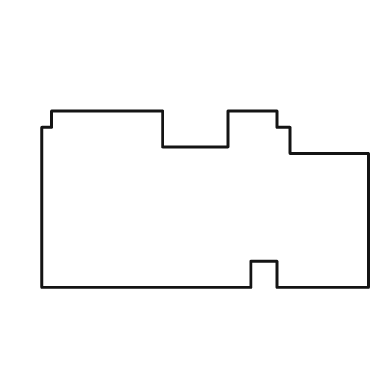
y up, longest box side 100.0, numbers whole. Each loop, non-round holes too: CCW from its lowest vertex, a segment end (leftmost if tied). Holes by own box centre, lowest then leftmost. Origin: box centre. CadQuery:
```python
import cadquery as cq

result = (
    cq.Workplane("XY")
    .moveTo(-50.0, -27.0)
    .lineTo(14.0, -27.0)
    .lineTo(14.0, -19.0)
    .lineTo(22.0, -19.0)
    .lineTo(22.0, -27.0)
    .lineTo(50.0, -27.0)
    .lineTo(50.0, 14.0)
    .lineTo(26.0, 14.0)
    .lineTo(26.0, 22.0)
    .lineTo(22.0, 22.0)
    .lineTo(22.0, 27.0)
    .lineTo(7.0, 27.0)
    .lineTo(7.0, 16.0)
    .lineTo(-13.0, 16.0)
    .lineTo(-13.0, 27.0)
    .lineTo(-47.0, 27.0)
    .lineTo(-47.0, 22.0)
    .lineTo(-50.0, 22.0)
    .close()
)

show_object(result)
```